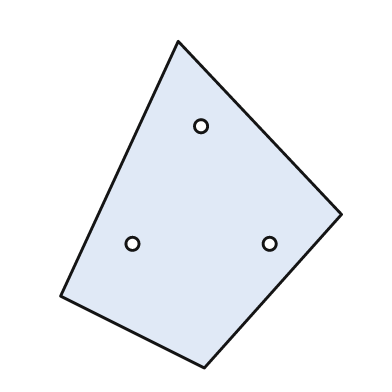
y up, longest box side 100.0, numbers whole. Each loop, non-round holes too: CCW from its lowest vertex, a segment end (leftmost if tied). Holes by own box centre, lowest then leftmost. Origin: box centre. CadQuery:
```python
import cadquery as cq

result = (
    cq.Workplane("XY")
    .moveTo(1.0, -50.0)
    .lineTo(43.0, -3.0)
    .lineTo(-7.0, 50.0)
    .lineTo(-43.0, -28.0)
    .close()
    .moveTo(-21.0, -12.0)
    .circle(2.0)
    .moveTo(21.0, -12.0)
    .circle(2.0)
    .moveTo(0.0, 24.0)
    .circle(2.0)
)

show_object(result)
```